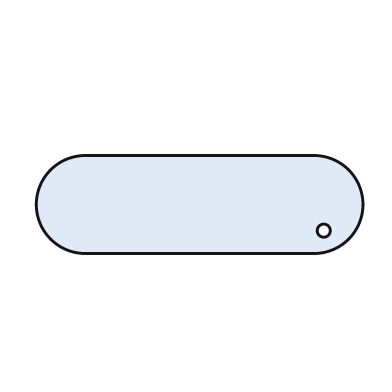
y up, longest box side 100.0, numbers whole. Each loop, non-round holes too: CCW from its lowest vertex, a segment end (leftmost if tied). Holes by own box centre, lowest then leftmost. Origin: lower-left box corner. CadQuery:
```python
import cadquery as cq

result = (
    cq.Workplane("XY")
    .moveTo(15.0, 0.0)
    .lineTo(85.0, 0.0)
    .threePointArc((100.0, 15.0), (85.0, 30.0))
    .lineTo(15.0, 30.0)
    .threePointArc((0.0, 15.0), (15.0, 0.0))
    .close()
    .moveTo(88.0, 7.0)
    .circle(2.0)
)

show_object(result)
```